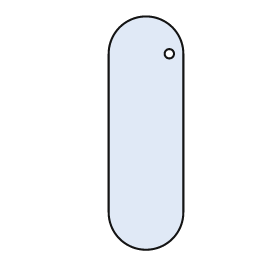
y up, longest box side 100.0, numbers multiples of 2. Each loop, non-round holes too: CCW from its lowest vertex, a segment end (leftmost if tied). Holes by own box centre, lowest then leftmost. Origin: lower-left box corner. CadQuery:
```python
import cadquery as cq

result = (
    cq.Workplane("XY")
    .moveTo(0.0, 16.0)
    .threePointArc((16.0, 0.0), (32.0, 16.0))
    .lineTo(32.0, 84.0)
    .threePointArc((16.0, 100.0), (0.0, 84.0))
    .close()
    .moveTo(26.0, 84.0)
    .circle(2.0)
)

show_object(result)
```